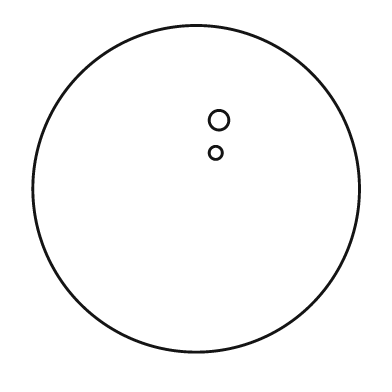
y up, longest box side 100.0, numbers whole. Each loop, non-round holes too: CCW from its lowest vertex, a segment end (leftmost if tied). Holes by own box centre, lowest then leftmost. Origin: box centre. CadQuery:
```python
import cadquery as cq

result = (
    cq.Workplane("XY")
    .moveTo(0.0, 0.0)
    .circle(50.0)
    .moveTo(6.0, 11.0)
    .circle(2.0)
    .moveTo(7.0, 21.0)
    .circle(3.0)
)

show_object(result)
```